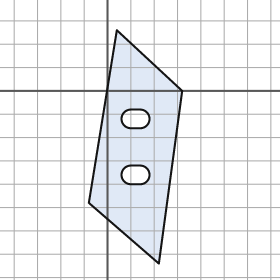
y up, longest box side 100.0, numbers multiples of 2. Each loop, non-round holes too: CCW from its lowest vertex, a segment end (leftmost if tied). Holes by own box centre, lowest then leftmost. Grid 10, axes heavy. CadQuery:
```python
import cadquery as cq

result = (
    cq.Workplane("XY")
    .moveTo(22.0, -74.0)
    .lineTo(32.0, 0.0)
    .lineTo(4.0, 26.0)
    .lineTo(-8.0, -48.0)
    .close()
    .moveTo(10.0, -40.0)
    .lineTo(14.0, -40.0)
    .threePointArc((18.0, -36.0), (14.0, -32.0))
    .lineTo(10.0, -32.0)
    .threePointArc((6.0, -36.0), (10.0, -40.0))
    .close()
    .moveTo(10.0, -16.0)
    .lineTo(14.0, -16.0)
    .threePointArc((18.0, -12.0), (14.0, -8.0))
    .lineTo(10.0, -8.0)
    .threePointArc((6.0, -12.0), (10.0, -16.0))
    .close()
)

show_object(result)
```